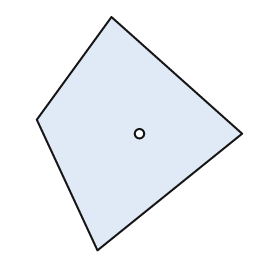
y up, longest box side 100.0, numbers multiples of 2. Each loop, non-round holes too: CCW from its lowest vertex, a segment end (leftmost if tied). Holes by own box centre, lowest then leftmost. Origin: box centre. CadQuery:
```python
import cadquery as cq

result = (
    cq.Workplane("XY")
    .moveTo(-18.0, -50.0)
    .lineTo(44.0, 0.0)
    .lineTo(-12.0, 50.0)
    .lineTo(-44.0, 6.0)
    .close()
    .moveTo(0.0, 0.0)
    .circle(2.0)
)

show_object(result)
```